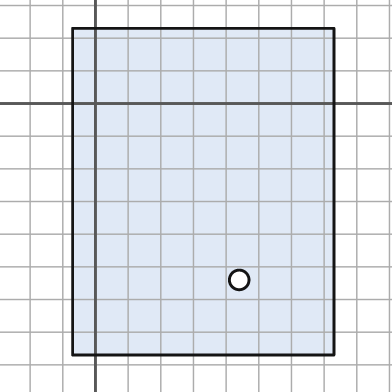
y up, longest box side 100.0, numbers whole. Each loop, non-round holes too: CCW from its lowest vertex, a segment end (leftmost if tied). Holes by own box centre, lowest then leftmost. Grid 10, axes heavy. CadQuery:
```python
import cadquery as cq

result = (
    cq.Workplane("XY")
    .moveTo(-7.0, -77.0)
    .lineTo(73.0, -77.0)
    .lineTo(73.0, 23.0)
    .lineTo(-7.0, 23.0)
    .close()
    .moveTo(44.0, -54.0)
    .circle(3.0)
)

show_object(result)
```